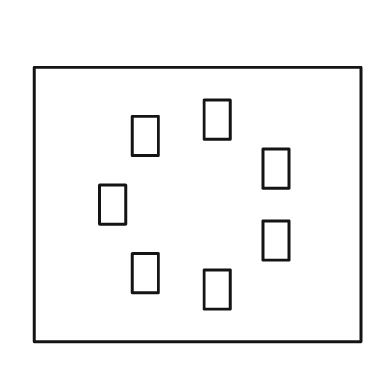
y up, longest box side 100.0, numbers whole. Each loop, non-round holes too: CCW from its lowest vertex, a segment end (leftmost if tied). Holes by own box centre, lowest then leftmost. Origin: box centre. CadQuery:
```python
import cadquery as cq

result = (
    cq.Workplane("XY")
    .moveTo(-50.0, -42.0)
    .lineTo(50.0, -42.0)
    .lineTo(50.0, 42.0)
    .lineTo(-50.0, 42.0)
    .close()
    .moveTo(2.0, -32.0)
    .lineTo(10.0, -32.0)
    .lineTo(10.0, -20.0)
    .lineTo(2.0, -20.0)
    .close()
    .moveTo(-20.0, -27.0)
    .lineTo(-12.0, -27.0)
    .lineTo(-12.0, -15.0)
    .lineTo(-20.0, -15.0)
    .close()
    .moveTo(20.0, -17.0)
    .lineTo(28.0, -17.0)
    .lineTo(28.0, -5.0)
    .lineTo(20.0, -5.0)
    .close()
    .moveTo(-30.0, -6.0)
    .lineTo(-22.0, -6.0)
    .lineTo(-22.0, 6.0)
    .lineTo(-30.0, 6.0)
    .close()
    .moveTo(20.0, 5.0)
    .lineTo(28.0, 5.0)
    .lineTo(28.0, 17.0)
    .lineTo(20.0, 17.0)
    .close()
    .moveTo(-20.0, 15.0)
    .lineTo(-12.0, 15.0)
    .lineTo(-12.0, 27.0)
    .lineTo(-20.0, 27.0)
    .close()
    .moveTo(2.0, 20.0)
    .lineTo(10.0, 20.0)
    .lineTo(10.0, 32.0)
    .lineTo(2.0, 32.0)
    .close()
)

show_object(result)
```